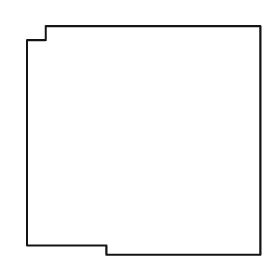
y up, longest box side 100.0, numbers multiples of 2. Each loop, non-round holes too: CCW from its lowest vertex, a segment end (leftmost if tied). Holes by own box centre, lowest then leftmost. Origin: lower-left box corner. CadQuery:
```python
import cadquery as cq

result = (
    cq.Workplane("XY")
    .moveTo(34.0, 0.0)
    .lineTo(100.0, 0.0)
    .lineTo(100.0, 98.0)
    .lineTo(8.0, 98.0)
    .lineTo(8.0, 92.0)
    .lineTo(0.0, 92.0)
    .lineTo(0.0, 4.0)
    .lineTo(34.0, 4.0)
    .close()
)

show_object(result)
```